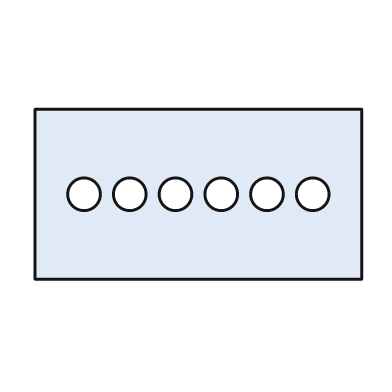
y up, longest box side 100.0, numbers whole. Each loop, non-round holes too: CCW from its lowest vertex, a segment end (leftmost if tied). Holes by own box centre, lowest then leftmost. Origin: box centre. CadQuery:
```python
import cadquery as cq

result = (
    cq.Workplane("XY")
    .moveTo(-50.0, -26.0)
    .lineTo(50.0, -26.0)
    .lineTo(50.0, 26.0)
    .lineTo(-50.0, 26.0)
    .close()
    .moveTo(-35.0, 0.0)
    .circle(5.0)
    .moveTo(-21.0, 0.0)
    .circle(5.0)
    .moveTo(-7.0, 0.0)
    .circle(5.0)
    .moveTo(7.0, 0.0)
    .circle(5.0)
    .moveTo(21.0, 0.0)
    .circle(5.0)
    .moveTo(35.0, 0.0)
    .circle(5.0)
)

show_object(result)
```